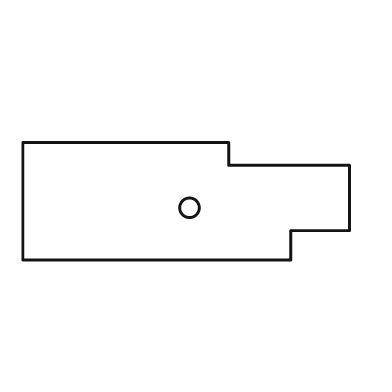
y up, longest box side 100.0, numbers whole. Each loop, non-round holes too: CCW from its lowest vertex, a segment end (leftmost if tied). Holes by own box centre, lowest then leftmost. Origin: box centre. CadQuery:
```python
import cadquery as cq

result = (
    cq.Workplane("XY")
    .moveTo(-50.0, -18.0)
    .lineTo(32.0, -18.0)
    .lineTo(32.0, -9.0)
    .lineTo(50.0, -9.0)
    .lineTo(50.0, 11.0)
    .lineTo(13.0, 11.0)
    .lineTo(13.0, 18.0)
    .lineTo(-50.0, 18.0)
    .close()
    .moveTo(1.0, -2.0)
    .circle(3.0)
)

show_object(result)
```